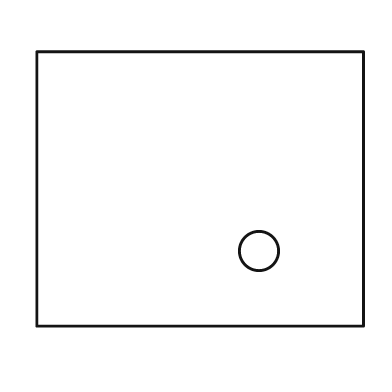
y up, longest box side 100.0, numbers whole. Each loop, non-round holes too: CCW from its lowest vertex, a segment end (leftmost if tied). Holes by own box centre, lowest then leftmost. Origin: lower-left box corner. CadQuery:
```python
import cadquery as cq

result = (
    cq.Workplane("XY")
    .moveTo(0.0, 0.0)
    .lineTo(100.0, 0.0)
    .lineTo(100.0, 84.0)
    .lineTo(0.0, 84.0)
    .close()
    .moveTo(68.0, 23.0)
    .circle(6.0)
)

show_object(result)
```